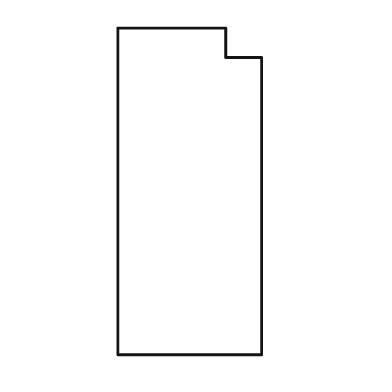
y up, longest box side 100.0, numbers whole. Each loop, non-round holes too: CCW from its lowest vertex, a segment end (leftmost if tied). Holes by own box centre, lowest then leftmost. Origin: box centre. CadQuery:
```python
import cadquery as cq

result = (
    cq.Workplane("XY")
    .moveTo(-22.0, -50.0)
    .lineTo(22.0, -50.0)
    .lineTo(22.0, 41.0)
    .lineTo(11.0, 41.0)
    .lineTo(11.0, 50.0)
    .lineTo(-22.0, 50.0)
    .close()
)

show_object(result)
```